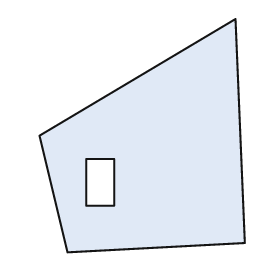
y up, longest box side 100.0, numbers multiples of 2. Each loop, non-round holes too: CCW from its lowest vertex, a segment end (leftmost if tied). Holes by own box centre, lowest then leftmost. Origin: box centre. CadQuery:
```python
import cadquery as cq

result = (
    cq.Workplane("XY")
    .moveTo(-32.0, -50.0)
    .lineTo(44.0, -46.0)
    .lineTo(40.0, 50.0)
    .lineTo(-44.0, 0.0)
    .close()
    .moveTo(-24.0, -30.0)
    .lineTo(-12.0, -30.0)
    .lineTo(-12.0, -10.0)
    .lineTo(-24.0, -10.0)
    .close()
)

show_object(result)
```